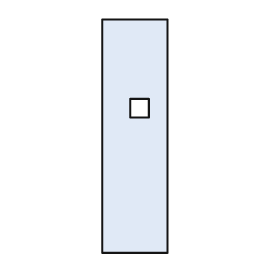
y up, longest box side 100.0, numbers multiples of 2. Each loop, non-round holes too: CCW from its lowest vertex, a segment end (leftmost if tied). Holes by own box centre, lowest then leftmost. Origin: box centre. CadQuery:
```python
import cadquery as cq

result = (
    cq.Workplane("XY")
    .moveTo(-14.0, -50.0)
    .lineTo(14.0, -50.0)
    .lineTo(14.0, 50.0)
    .lineTo(-14.0, 50.0)
    .close()
    .moveTo(-2.0, 8.0)
    .lineTo(6.0, 8.0)
    .lineTo(6.0, 16.0)
    .lineTo(-2.0, 16.0)
    .close()
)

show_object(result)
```